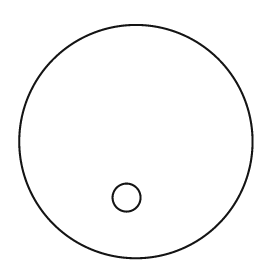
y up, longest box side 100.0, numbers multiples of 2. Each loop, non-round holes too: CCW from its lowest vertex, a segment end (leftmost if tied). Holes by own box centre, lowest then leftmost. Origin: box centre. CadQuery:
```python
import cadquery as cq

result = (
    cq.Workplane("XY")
    .moveTo(0.0, 0.0)
    .circle(50.0)
    .moveTo(-4.0, -24.0)
    .circle(6.0)
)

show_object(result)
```